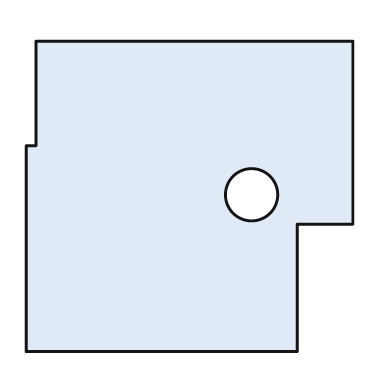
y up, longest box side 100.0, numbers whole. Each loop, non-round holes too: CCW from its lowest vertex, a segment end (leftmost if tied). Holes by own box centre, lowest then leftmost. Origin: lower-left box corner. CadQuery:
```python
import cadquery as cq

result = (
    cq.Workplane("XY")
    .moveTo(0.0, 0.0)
    .lineTo(83.0, 0.0)
    .lineTo(83.0, 39.0)
    .lineTo(100.0, 39.0)
    .lineTo(100.0, 95.0)
    .lineTo(3.0, 95.0)
    .lineTo(3.0, 63.0)
    .lineTo(0.0, 63.0)
    .close()
    .moveTo(69.0, 48.0)
    .circle(8.0)
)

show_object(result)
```